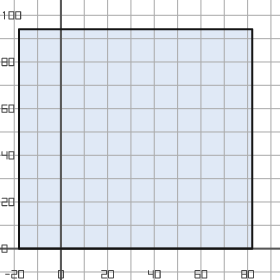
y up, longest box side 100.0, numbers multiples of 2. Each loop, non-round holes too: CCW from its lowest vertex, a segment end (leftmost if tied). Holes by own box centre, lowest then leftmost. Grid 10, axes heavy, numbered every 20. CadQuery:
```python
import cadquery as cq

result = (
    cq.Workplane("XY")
    .moveTo(-18.0, 0.0)
    .lineTo(82.0, 0.0)
    .lineTo(82.0, 94.0)
    .lineTo(-18.0, 94.0)
    .close()
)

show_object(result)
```